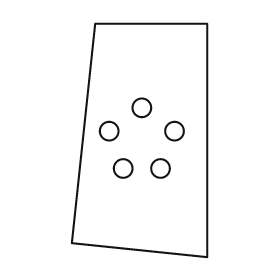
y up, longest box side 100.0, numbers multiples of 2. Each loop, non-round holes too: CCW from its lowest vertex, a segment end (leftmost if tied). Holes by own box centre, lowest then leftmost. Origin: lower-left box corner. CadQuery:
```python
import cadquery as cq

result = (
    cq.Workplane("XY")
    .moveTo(58.0, 0.0)
    .lineTo(58.0, 100.0)
    .lineTo(10.0, 100.0)
    .lineTo(0.0, 6.0)
    .close()
    .moveTo(22.0, 38.0)
    .circle(4.0)
    .moveTo(38.0, 38.0)
    .circle(4.0)
    .moveTo(16.0, 54.0)
    .circle(4.0)
    .moveTo(44.0, 54.0)
    .circle(4.0)
    .moveTo(30.0, 64.0)
    .circle(4.0)
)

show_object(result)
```